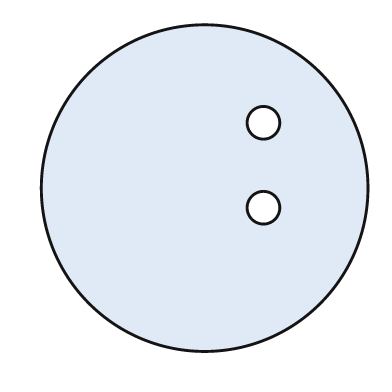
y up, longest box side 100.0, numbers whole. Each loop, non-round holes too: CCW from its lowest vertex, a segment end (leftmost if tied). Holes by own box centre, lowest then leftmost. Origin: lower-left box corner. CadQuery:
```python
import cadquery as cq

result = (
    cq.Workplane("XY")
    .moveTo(50.0, 50.0)
    .circle(50.0)
    .moveTo(68.0, 44.0)
    .circle(5.0)
    .moveTo(68.0, 70.0)
    .circle(5.0)
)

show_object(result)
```